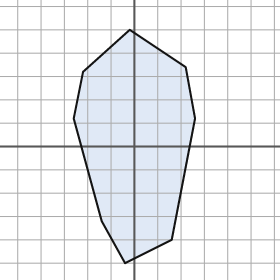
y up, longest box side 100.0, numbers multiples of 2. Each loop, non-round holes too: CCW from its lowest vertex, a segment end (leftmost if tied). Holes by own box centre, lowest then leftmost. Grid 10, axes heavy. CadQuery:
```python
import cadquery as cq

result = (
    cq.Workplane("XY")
    .moveTo(-4.0, -50.0)
    .lineTo(16.0, -40.0)
    .lineTo(26.0, 12.0)
    .lineTo(22.0, 34.0)
    .lineTo(-2.0, 50.0)
    .lineTo(-22.0, 32.0)
    .lineTo(-26.0, 12.0)
    .lineTo(-14.0, -32.0)
    .close()
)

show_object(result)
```